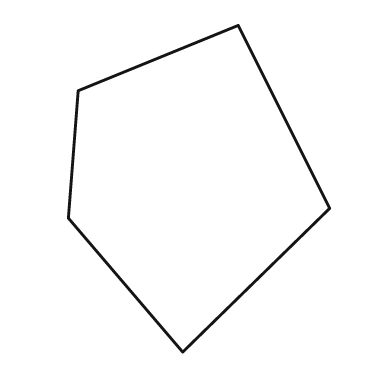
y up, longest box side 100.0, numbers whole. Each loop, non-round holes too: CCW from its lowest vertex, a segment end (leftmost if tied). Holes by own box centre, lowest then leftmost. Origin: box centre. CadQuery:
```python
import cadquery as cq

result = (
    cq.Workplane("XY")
    .moveTo(-5.0, -50.0)
    .lineTo(40.0, -6.0)
    .lineTo(12.0, 50.0)
    .lineTo(-37.0, 30.0)
    .lineTo(-40.0, -9.0)
    .close()
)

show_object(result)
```